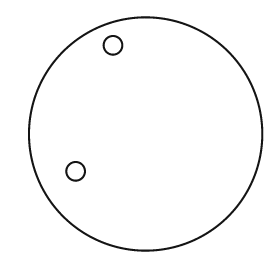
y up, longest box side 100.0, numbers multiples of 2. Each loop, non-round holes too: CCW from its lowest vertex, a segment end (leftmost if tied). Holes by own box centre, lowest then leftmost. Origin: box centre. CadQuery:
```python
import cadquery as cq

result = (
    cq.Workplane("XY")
    .moveTo(0.0, 0.0)
    .circle(50.0)
    .moveTo(-30.0, -16.0)
    .circle(4.0)
    .moveTo(-14.0, 38.0)
    .circle(4.0)
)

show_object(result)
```